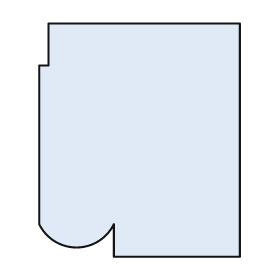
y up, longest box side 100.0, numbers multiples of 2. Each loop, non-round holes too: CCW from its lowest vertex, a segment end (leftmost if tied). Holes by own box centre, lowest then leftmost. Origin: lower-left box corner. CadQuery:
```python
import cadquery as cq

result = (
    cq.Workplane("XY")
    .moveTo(32.0, 0.0)
    .lineTo(86.0, 0.0)
    .lineTo(86.0, 100.0)
    .lineTo(4.0, 100.0)
    .lineTo(4.0, 82.0)
    .lineTo(0.0, 82.0)
    .lineTo(0.0, 14.0)
    .threePointArc((16.0, 4.0), (32.0, 14.0))
    .close()
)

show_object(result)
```